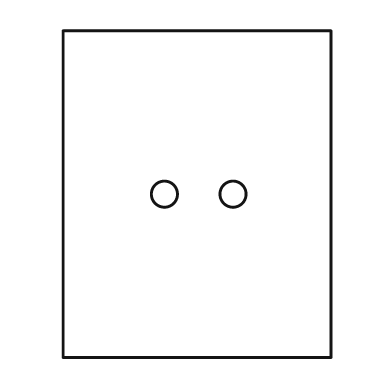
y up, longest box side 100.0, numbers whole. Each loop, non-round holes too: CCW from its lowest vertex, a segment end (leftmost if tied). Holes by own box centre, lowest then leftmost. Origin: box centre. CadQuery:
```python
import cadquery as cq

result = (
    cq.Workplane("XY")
    .moveTo(-41.0, -50.0)
    .lineTo(41.0, -50.0)
    .lineTo(41.0, 50.0)
    .lineTo(-41.0, 50.0)
    .close()
    .moveTo(-10.0, 0.0)
    .circle(4.0)
    .moveTo(11.0, 0.0)
    .circle(4.0)
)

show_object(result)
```